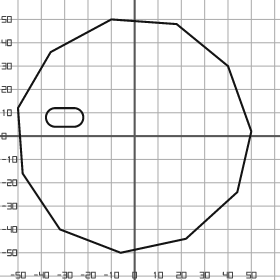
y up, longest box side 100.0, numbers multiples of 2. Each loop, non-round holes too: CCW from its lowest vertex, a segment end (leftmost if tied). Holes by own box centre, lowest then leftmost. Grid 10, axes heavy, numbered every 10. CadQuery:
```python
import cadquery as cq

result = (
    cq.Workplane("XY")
    .moveTo(-6.0, -50.0)
    .lineTo(22.0, -44.0)
    .lineTo(44.0, -24.0)
    .lineTo(50.0, 2.0)
    .lineTo(40.0, 30.0)
    .lineTo(18.0, 48.0)
    .lineTo(-10.0, 50.0)
    .lineTo(-36.0, 36.0)
    .lineTo(-50.0, 12.0)
    .lineTo(-48.0, -16.0)
    .lineTo(-32.0, -40.0)
    .close()
    .moveTo(-34.0, 4.0)
    .lineTo(-26.0, 4.0)
    .threePointArc((-22.0, 8.0), (-26.0, 12.0))
    .lineTo(-34.0, 12.0)
    .threePointArc((-38.0, 8.0), (-34.0, 4.0))
    .close()
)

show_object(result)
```